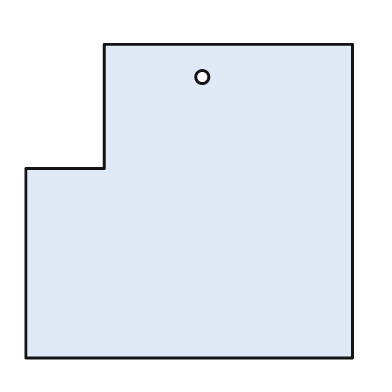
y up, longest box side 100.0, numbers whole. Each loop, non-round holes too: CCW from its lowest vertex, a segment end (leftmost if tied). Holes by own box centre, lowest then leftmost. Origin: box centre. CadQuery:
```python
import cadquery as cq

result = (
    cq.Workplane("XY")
    .moveTo(-50.0, -48.0)
    .lineTo(50.0, -48.0)
    .lineTo(50.0, 48.0)
    .lineTo(-26.0, 48.0)
    .lineTo(-26.0, 10.0)
    .lineTo(-50.0, 10.0)
    .close()
    .moveTo(4.0, 38.0)
    .circle(2.0)
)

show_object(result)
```